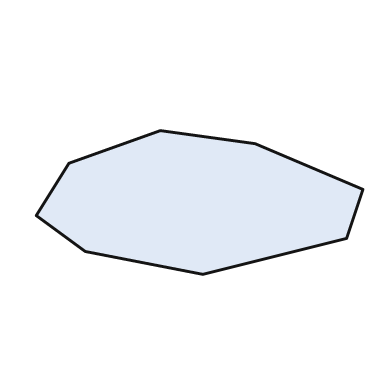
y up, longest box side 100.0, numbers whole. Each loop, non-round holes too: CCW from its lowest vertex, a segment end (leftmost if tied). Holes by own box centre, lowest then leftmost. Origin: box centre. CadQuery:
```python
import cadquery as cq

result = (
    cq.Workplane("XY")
    .moveTo(1.0, -22.0)
    .lineTo(45.0, -11.0)
    .lineTo(50.0, 4.0)
    .lineTo(17.0, 18.0)
    .lineTo(-12.0, 22.0)
    .lineTo(-40.0, 12.0)
    .lineTo(-50.0, -4.0)
    .lineTo(-35.0, -15.0)
    .close()
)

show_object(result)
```